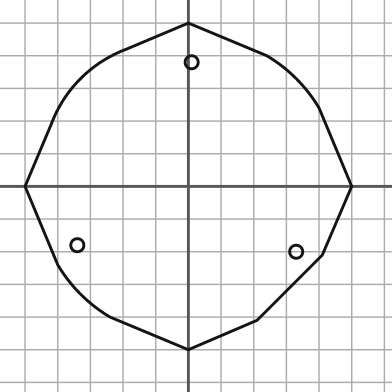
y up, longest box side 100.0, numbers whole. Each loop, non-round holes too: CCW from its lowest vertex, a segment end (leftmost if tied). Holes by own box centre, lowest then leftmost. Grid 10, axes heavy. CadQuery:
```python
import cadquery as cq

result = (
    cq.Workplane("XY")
    .moveTo(0.0, -50.0)
    .lineTo(21.0, -41.0)
    .lineTo(41.0, -21.0)
    .lineTo(50.0, 0.0)
    .lineTo(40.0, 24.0)
    .threePointArc((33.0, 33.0), (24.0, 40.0))
    .lineTo(0.0, 50.0)
    .lineTo(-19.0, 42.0)
    .threePointArc((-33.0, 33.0), (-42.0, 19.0))
    .lineTo(-50.0, 0.0)
    .lineTo(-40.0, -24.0)
    .threePointArc((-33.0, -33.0), (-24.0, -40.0))
    .close()
    .moveTo(33.0, -20.0)
    .circle(2.0)
    .moveTo(-34.0, -18.0)
    .circle(2.0)
    .moveTo(1.0, 38.0)
    .circle(2.0)
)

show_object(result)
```